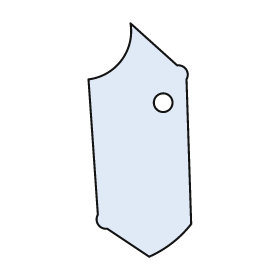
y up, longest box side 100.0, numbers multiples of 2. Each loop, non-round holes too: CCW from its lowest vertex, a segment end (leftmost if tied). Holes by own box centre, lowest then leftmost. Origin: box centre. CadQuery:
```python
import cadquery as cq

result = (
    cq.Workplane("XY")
    .moveTo(4.0, -50.0)
    .threePointArc((14.0, -44.0), (22.0, -36.0))
    .lineTo(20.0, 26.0)
    .threePointArc((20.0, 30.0), (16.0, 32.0))
    .lineTo(-4.0, 50.0)
    .threePointArc((-8.0, 34.0), (-22.0, 26.0))
    .lineTo(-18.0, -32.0)
    .threePointArc((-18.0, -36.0), (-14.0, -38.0))
    .close()
    .moveTo(10.0, 16.0)
    .circle(4.0)
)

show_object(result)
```